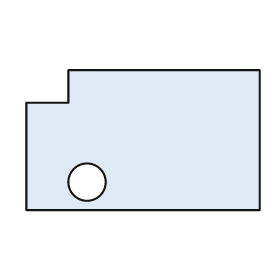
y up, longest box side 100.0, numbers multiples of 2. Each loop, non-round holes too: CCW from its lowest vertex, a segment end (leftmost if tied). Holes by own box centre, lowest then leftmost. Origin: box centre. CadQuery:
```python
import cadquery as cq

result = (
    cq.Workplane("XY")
    .moveTo(-50.0, -30.0)
    .lineTo(50.0, -30.0)
    .lineTo(50.0, 30.0)
    .lineTo(-32.0, 30.0)
    .lineTo(-32.0, 16.0)
    .lineTo(-50.0, 16.0)
    .close()
    .moveTo(-24.0, -18.0)
    .circle(8.0)
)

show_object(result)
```